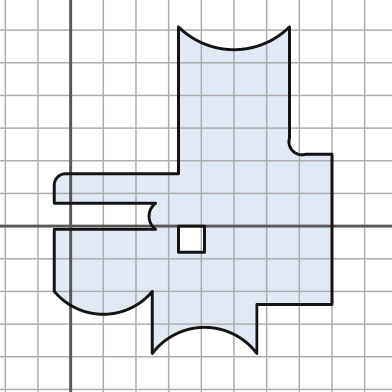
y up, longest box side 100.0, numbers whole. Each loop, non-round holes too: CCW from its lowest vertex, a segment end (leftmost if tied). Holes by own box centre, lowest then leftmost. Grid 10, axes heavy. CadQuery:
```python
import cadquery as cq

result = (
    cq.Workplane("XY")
    .moveTo(25.0, -39.0)
    .threePointArc((41.0, -31.0), (57.0, -39.0))
    .lineTo(57.0, -24.0)
    .lineTo(80.0, -24.0)
    .lineTo(80.0, 22.0)
    .lineTo(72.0, 22.0)
    .threePointArc((68.0, 23.0), (67.0, 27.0))
    .lineTo(67.0, 61.0)
    .threePointArc((50.0, 54.0), (33.0, 61.0))
    .lineTo(33.0, 16.0)
    .lineTo(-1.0, 16.0)
    .threePointArc((-4.0, 15.0), (-5.0, 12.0))
    .lineTo(-5.0, 7.0)
    .lineTo(26.0, 7.0)
    .threePointArc((24.0, 3.0), (26.0, -1.0))
    .lineTo(-5.0, -1.0)
    .lineTo(-5.0, -20.0)
    .threePointArc((10.0, -27.0), (25.0, -20.0))
    .close()
    .moveTo(33.0, -8.0)
    .lineTo(41.0, -8.0)
    .lineTo(41.0, 0.0)
    .lineTo(33.0, 0.0)
    .close()
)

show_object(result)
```